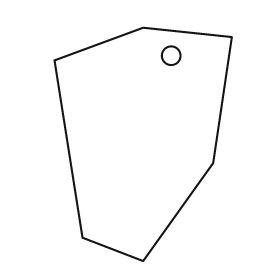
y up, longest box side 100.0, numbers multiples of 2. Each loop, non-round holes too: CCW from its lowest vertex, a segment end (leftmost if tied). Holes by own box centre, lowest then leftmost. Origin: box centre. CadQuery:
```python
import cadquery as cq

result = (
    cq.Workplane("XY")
    .moveTo(0.0, -50.0)
    .lineTo(30.0, -8.0)
    .lineTo(38.0, 46.0)
    .lineTo(0.0, 50.0)
    .lineTo(-38.0, 36.0)
    .lineTo(-26.0, -40.0)
    .close()
    .moveTo(12.0, 38.0)
    .circle(4.0)
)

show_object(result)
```